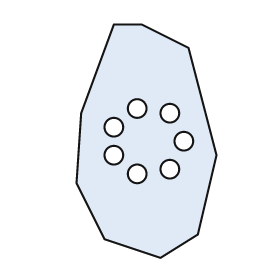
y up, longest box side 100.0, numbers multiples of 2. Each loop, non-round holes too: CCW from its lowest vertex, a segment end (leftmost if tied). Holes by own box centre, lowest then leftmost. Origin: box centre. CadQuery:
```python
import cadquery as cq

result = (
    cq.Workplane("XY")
    .moveTo(6.0, -50.0)
    .lineTo(22.0, -40.0)
    .lineTo(30.0, -6.0)
    .lineTo(18.0, 40.0)
    .lineTo(-2.0, 50.0)
    .lineTo(-14.0, 50.0)
    .lineTo(-28.0, 12.0)
    .lineTo(-30.0, -18.0)
    .lineTo(-18.0, -42.0)
    .close()
    .moveTo(-4.0, -14.0)
    .circle(4.0)
    .moveTo(10.0, -12.0)
    .circle(4.0)
    .moveTo(-14.0, -6.0)
    .circle(4.0)
    .moveTo(16.0, 0.0)
    .circle(4.0)
    .moveTo(-14.0, 6.0)
    .circle(4.0)
    .moveTo(10.0, 12.0)
    .circle(4.0)
    .moveTo(-4.0, 14.0)
    .circle(4.0)
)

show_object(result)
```